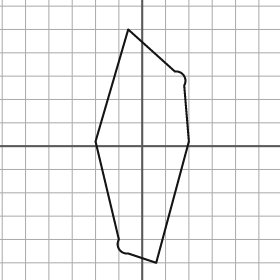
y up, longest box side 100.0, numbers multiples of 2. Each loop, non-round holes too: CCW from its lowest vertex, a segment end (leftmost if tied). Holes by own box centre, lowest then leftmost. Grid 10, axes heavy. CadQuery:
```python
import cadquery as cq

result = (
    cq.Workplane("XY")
    .moveTo(6.0, -50.0)
    .lineTo(20.0, 2.0)
    .lineTo(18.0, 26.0)
    .threePointArc((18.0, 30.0), (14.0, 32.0))
    .lineTo(-6.0, 50.0)
    .lineTo(-20.0, 2.0)
    .lineTo(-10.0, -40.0)
    .threePointArc((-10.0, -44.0), (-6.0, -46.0))
    .close()
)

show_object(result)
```